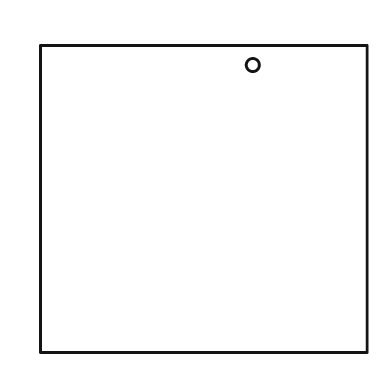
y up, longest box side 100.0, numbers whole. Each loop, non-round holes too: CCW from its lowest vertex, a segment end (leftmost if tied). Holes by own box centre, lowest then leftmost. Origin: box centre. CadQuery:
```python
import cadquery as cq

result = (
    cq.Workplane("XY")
    .moveTo(-50.0, -47.0)
    .lineTo(50.0, -47.0)
    .lineTo(50.0, 47.0)
    .lineTo(-50.0, 47.0)
    .close()
    .moveTo(15.0, 41.0)
    .circle(2.0)
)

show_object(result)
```